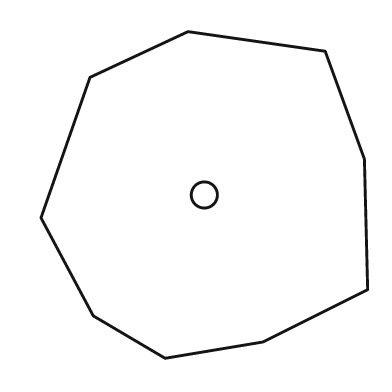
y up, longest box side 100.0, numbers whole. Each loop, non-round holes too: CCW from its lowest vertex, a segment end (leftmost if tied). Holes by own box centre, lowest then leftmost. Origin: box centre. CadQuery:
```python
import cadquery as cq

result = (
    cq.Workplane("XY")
    .moveTo(-12.0, -50.0)
    .lineTo(18.0, -45.0)
    .lineTo(50.0, -29.0)
    .lineTo(49.0, 11.0)
    .lineTo(37.0, 44.0)
    .lineTo(-5.0, 50.0)
    .lineTo(-35.0, 36.0)
    .lineTo(-50.0, -7.0)
    .lineTo(-34.0, -37.0)
    .close()
    .moveTo(0.0, 0.0)
    .circle(4.0)
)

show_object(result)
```